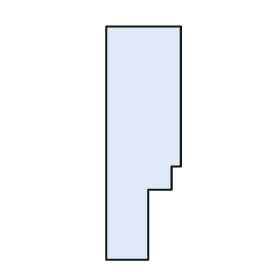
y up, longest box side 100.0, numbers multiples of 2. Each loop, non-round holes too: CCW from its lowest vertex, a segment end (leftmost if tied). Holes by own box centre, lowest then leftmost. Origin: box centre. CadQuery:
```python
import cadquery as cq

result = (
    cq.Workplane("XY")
    .moveTo(-16.0, -50.0)
    .lineTo(2.0, -50.0)
    .lineTo(2.0, -20.0)
    .lineTo(12.0, -20.0)
    .lineTo(12.0, -10.0)
    .lineTo(16.0, -10.0)
    .lineTo(16.0, 50.0)
    .lineTo(-16.0, 50.0)
    .close()
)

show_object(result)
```